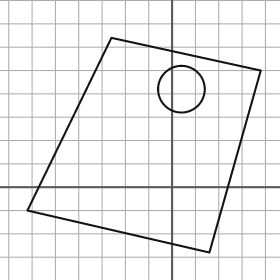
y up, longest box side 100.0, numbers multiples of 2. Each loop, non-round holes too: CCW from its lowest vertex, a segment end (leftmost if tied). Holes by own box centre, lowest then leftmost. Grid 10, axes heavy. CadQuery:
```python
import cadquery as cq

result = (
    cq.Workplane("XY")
    .moveTo(16.0, -28.0)
    .lineTo(38.0, 50.0)
    .lineTo(-26.0, 64.0)
    .lineTo(-62.0, -10.0)
    .close()
    .moveTo(4.0, 42.0)
    .circle(10.0)
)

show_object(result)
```